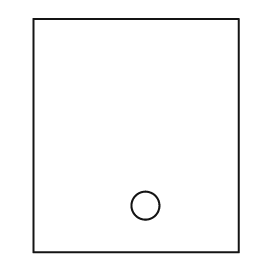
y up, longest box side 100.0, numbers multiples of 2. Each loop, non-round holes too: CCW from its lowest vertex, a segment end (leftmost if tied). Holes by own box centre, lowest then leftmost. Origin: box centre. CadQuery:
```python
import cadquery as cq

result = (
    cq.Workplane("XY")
    .moveTo(-44.0, -50.0)
    .lineTo(44.0, -50.0)
    .lineTo(44.0, 50.0)
    .lineTo(-44.0, 50.0)
    .close()
    .moveTo(4.0, -30.0)
    .circle(6.0)
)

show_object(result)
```